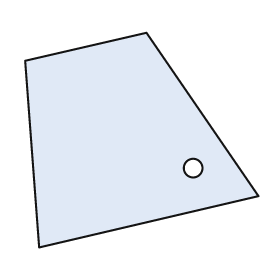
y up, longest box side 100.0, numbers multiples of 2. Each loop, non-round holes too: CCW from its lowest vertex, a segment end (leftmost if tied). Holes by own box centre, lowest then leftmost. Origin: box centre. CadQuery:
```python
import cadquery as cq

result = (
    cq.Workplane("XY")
    .moveTo(-44.0, -46.0)
    .lineTo(50.0, -24.0)
    .lineTo(2.0, 46.0)
    .lineTo(-50.0, 34.0)
    .close()
    .moveTo(22.0, -12.0)
    .circle(4.0)
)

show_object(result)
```